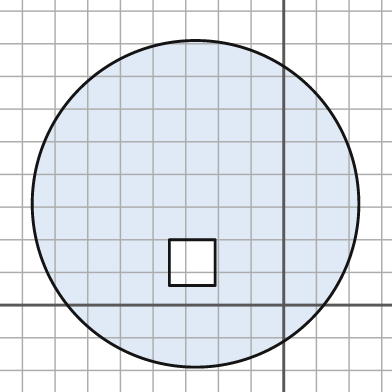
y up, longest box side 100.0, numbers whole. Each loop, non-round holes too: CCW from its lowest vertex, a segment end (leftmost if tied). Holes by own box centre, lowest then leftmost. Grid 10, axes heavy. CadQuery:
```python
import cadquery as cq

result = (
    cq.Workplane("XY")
    .moveTo(-27.0, 31.0)
    .circle(50.0)
    .moveTo(-35.0, 6.0)
    .lineTo(-21.0, 6.0)
    .lineTo(-21.0, 20.0)
    .lineTo(-35.0, 20.0)
    .close()
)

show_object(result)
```